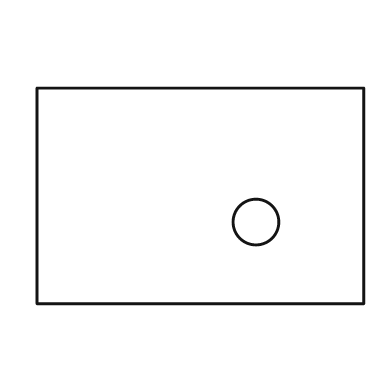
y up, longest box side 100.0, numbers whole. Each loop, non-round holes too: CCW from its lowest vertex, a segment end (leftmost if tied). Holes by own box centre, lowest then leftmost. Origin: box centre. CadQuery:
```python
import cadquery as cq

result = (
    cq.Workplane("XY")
    .moveTo(-50.0, -33.0)
    .lineTo(50.0, -33.0)
    .lineTo(50.0, 33.0)
    .lineTo(-50.0, 33.0)
    .close()
    .moveTo(17.0, -8.0)
    .circle(7.0)
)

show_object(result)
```